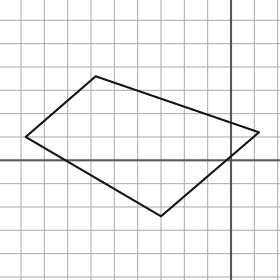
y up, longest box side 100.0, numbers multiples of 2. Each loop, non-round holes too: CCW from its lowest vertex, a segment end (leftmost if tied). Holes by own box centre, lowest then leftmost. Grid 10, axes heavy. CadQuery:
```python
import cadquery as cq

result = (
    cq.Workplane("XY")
    .moveTo(-30.0, -24.0)
    .lineTo(12.0, 12.0)
    .lineTo(-58.0, 36.0)
    .lineTo(-88.0, 10.0)
    .close()
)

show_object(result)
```